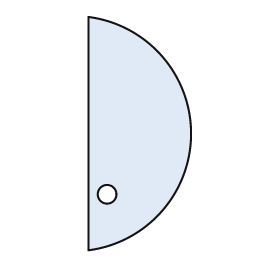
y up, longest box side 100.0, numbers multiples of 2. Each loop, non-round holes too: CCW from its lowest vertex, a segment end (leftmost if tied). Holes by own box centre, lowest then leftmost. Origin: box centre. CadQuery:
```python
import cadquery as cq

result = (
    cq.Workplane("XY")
    .moveTo(-22.0, -50.0)
    .threePointArc((22.0, 0.0), (-22.0, 50.0))
    .close()
    .moveTo(-14.0, -26.0)
    .circle(4.0)
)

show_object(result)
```